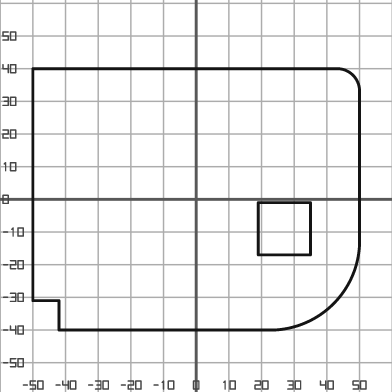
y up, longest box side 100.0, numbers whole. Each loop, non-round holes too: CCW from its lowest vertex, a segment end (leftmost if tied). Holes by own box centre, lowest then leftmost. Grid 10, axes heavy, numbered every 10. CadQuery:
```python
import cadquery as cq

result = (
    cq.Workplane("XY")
    .moveTo(-42.0, -40.0)
    .lineTo(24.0, -40.0)
    .threePointArc((42.0, -32.0), (50.0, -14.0))
    .lineTo(50.0, 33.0)
    .threePointArc((48.0, 38.0), (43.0, 40.0))
    .lineTo(-50.0, 40.0)
    .lineTo(-50.0, -31.0)
    .lineTo(-42.0, -31.0)
    .close()
    .moveTo(19.0, -17.0)
    .lineTo(35.0, -17.0)
    .lineTo(35.0, -1.0)
    .lineTo(19.0, -1.0)
    .close()
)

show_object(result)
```